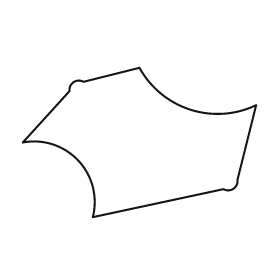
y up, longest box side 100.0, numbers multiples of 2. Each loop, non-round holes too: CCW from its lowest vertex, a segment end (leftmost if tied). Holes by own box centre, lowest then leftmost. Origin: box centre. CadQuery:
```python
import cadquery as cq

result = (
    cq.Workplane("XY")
    .moveTo(-20.0, -32.0)
    .lineTo(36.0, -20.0)
    .threePointArc((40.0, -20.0), (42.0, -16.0))
    .lineTo(50.0, 16.0)
    .threePointArc((22.0, 14.0), (0.0, 32.0))
    .lineTo(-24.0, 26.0)
    .threePointArc((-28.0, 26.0), (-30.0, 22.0))
    .lineTo(-50.0, 0.0)
    .threePointArc((-26.0, -8.0), (-20.0, -32.0))
    .close()
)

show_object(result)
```